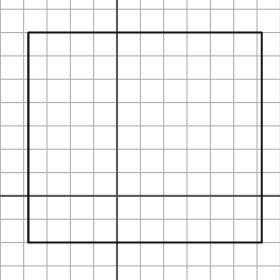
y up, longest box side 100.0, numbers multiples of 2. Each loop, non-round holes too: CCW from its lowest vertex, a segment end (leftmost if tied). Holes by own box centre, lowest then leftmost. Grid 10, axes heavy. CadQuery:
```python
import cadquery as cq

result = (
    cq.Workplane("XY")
    .moveTo(-38.0, -20.0)
    .lineTo(62.0, -20.0)
    .lineTo(62.0, 70.0)
    .lineTo(-38.0, 70.0)
    .close()
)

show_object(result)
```